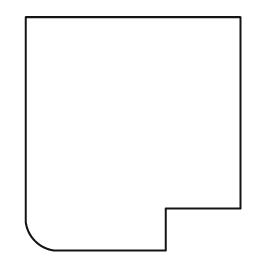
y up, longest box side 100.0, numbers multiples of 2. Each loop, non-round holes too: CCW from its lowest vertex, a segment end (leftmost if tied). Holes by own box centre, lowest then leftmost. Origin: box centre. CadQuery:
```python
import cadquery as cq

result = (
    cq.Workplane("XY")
    .moveTo(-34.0, -50.0)
    .lineTo(14.0, -50.0)
    .lineTo(14.0, -32.0)
    .lineTo(46.0, -32.0)
    .lineTo(46.0, 50.0)
    .lineTo(-46.0, 50.0)
    .lineTo(-46.0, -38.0)
    .threePointArc((-42.0, -46.0), (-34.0, -50.0))
    .close()
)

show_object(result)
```